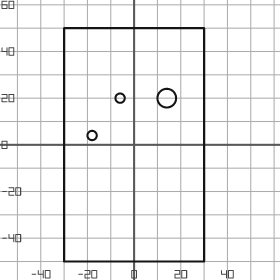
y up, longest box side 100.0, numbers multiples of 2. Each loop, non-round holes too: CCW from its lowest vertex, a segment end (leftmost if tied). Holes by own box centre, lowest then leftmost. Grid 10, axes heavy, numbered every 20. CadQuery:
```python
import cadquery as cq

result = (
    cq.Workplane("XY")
    .moveTo(-30.0, -50.0)
    .lineTo(30.0, -50.0)
    .lineTo(30.0, 50.0)
    .lineTo(-30.0, 50.0)
    .close()
    .moveTo(-18.0, 4.0)
    .circle(2.0)
    .moveTo(-6.0, 20.0)
    .circle(2.0)
    .moveTo(14.0, 20.0)
    .circle(4.0)
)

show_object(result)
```